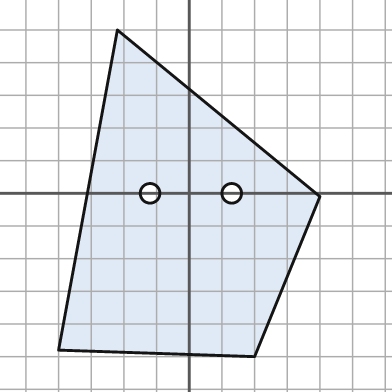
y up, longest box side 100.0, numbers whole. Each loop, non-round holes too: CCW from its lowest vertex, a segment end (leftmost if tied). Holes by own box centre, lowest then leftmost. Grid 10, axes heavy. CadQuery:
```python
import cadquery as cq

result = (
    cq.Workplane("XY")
    .moveTo(20.0, -50.0)
    .lineTo(40.0, -1.0)
    .lineTo(-22.0, 50.0)
    .lineTo(-40.0, -48.0)
    .close()
    .moveTo(-12.0, 0.0)
    .circle(3.0)
    .moveTo(13.0, 0.0)
    .circle(3.0)
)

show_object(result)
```